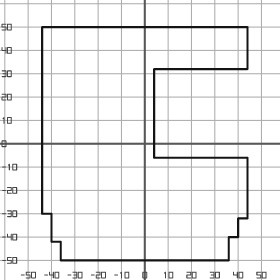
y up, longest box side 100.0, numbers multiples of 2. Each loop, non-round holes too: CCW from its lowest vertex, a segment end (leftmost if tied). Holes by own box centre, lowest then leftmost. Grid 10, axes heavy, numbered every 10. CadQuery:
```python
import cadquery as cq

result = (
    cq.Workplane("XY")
    .moveTo(-36.0, -50.0)
    .lineTo(36.0, -50.0)
    .lineTo(36.0, -40.0)
    .lineTo(40.0, -40.0)
    .lineTo(40.0, -32.0)
    .lineTo(44.0, -32.0)
    .lineTo(44.0, -6.0)
    .lineTo(4.0, -6.0)
    .lineTo(4.0, 32.0)
    .lineTo(44.0, 32.0)
    .lineTo(44.0, 50.0)
    .lineTo(-44.0, 50.0)
    .lineTo(-44.0, -30.0)
    .lineTo(-40.0, -30.0)
    .lineTo(-40.0, -42.0)
    .lineTo(-36.0, -42.0)
    .close()
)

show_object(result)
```